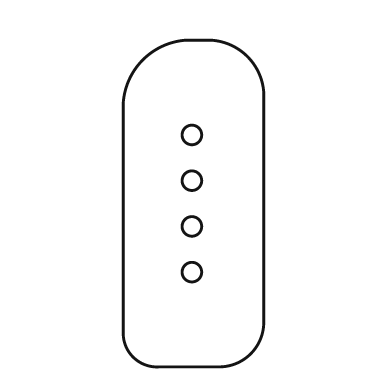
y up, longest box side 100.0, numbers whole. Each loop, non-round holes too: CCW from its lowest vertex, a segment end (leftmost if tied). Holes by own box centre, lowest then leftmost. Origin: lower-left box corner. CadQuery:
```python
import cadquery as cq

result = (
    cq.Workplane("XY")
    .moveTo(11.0, 0.0)
    .lineTo(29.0, 0.0)
    .threePointArc((39.0, 4.0), (43.0, 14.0))
    .lineTo(43.0, 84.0)
    .threePointArc((38.0, 95.0), (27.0, 100.0))
    .lineTo(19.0, 100.0)
    .threePointArc((6.0, 94.0), (0.0, 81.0))
    .lineTo(0.0, 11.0)
    .threePointArc((3.0, 3.0), (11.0, 0.0))
    .close()
    .moveTo(21.0, 29.0)
    .circle(3.0)
    .moveTo(21.0, 43.0)
    .circle(3.0)
    .moveTo(21.0, 57.0)
    .circle(3.0)
    .moveTo(21.0, 71.0)
    .circle(3.0)
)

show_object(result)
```